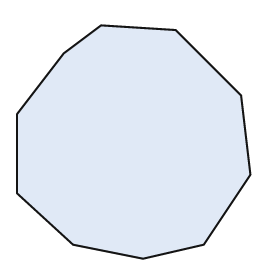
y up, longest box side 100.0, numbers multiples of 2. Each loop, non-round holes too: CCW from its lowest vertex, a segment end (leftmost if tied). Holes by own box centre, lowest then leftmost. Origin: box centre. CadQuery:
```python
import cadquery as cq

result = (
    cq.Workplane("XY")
    .moveTo(4.0, -50.0)
    .lineTo(30.0, -44.0)
    .lineTo(50.0, -14.0)
    .lineTo(46.0, 20.0)
    .lineTo(18.0, 48.0)
    .lineTo(-14.0, 50.0)
    .lineTo(-30.0, 38.0)
    .lineTo(-50.0, 12.0)
    .lineTo(-50.0, -22.0)
    .lineTo(-26.0, -44.0)
    .close()
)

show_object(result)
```